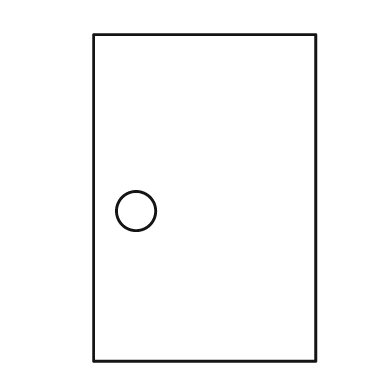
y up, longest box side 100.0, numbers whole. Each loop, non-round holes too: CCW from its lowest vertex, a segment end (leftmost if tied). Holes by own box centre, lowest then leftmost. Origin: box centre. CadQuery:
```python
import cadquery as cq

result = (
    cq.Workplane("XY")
    .moveTo(-34.0, -50.0)
    .lineTo(34.0, -50.0)
    .lineTo(34.0, 50.0)
    .lineTo(-34.0, 50.0)
    .close()
    .moveTo(-21.0, -4.0)
    .circle(6.0)
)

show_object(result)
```